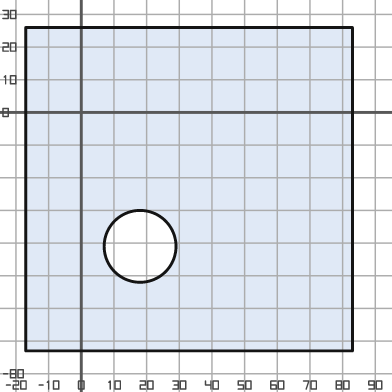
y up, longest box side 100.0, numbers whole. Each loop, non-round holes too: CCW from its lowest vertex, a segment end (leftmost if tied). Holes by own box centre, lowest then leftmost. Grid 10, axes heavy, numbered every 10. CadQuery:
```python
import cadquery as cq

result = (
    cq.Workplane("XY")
    .moveTo(-17.0, -73.0)
    .lineTo(83.0, -73.0)
    .lineTo(83.0, 26.0)
    .lineTo(-17.0, 26.0)
    .close()
    .moveTo(18.0, -41.0)
    .circle(11.0)
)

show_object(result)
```